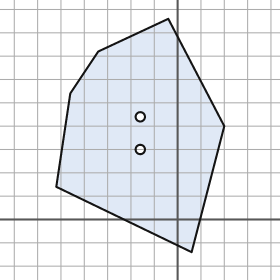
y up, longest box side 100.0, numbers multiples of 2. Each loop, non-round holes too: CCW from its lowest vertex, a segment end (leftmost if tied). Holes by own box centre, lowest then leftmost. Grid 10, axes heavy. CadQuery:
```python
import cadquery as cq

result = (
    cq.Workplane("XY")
    .moveTo(6.0, -14.0)
    .lineTo(20.0, 40.0)
    .lineTo(-4.0, 86.0)
    .lineTo(-34.0, 72.0)
    .lineTo(-46.0, 54.0)
    .lineTo(-52.0, 14.0)
    .close()
    .moveTo(-16.0, 30.0)
    .circle(2.0)
    .moveTo(-16.0, 44.0)
    .circle(2.0)
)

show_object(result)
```